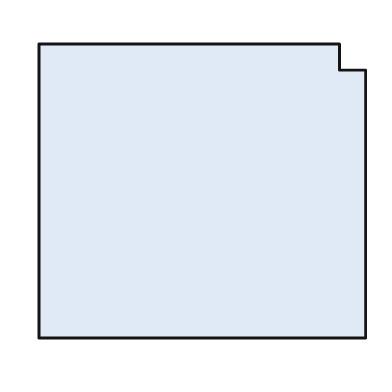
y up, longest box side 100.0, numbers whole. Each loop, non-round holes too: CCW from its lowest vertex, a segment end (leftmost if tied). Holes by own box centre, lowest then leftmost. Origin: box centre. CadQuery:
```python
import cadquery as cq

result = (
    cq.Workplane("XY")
    .moveTo(-50.0, -45.0)
    .lineTo(50.0, -45.0)
    .lineTo(50.0, 37.0)
    .lineTo(42.0, 37.0)
    .lineTo(42.0, 45.0)
    .lineTo(-50.0, 45.0)
    .close()
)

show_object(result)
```